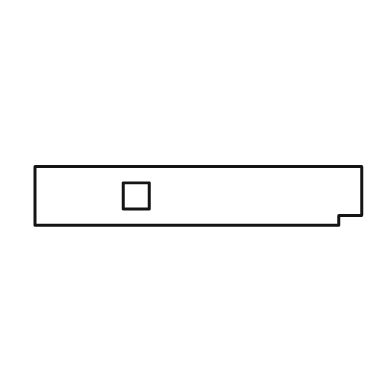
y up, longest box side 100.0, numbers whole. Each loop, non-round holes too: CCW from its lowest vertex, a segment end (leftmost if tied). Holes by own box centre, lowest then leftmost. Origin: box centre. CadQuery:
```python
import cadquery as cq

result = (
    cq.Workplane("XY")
    .moveTo(-50.0, -9.0)
    .lineTo(43.0, -9.0)
    .lineTo(43.0, -6.0)
    .lineTo(50.0, -6.0)
    .lineTo(50.0, 9.0)
    .lineTo(-50.0, 9.0)
    .close()
    .moveTo(-23.0, -4.0)
    .lineTo(-15.0, -4.0)
    .lineTo(-15.0, 4.0)
    .lineTo(-23.0, 4.0)
    .close()
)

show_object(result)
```